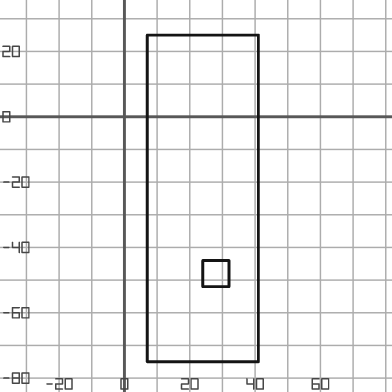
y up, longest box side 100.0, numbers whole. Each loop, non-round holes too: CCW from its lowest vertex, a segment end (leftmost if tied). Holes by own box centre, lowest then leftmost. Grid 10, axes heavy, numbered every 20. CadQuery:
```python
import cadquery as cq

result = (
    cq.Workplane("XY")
    .moveTo(7.0, -75.0)
    .lineTo(41.0, -75.0)
    .lineTo(41.0, 25.0)
    .lineTo(7.0, 25.0)
    .close()
    .moveTo(24.0, -52.0)
    .lineTo(32.0, -52.0)
    .lineTo(32.0, -44.0)
    .lineTo(24.0, -44.0)
    .close()
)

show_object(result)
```